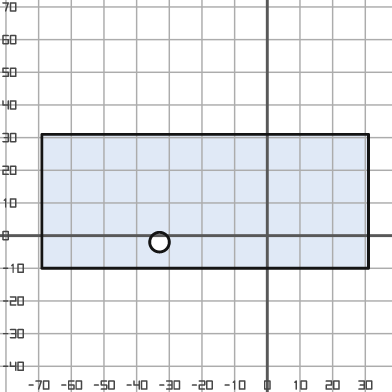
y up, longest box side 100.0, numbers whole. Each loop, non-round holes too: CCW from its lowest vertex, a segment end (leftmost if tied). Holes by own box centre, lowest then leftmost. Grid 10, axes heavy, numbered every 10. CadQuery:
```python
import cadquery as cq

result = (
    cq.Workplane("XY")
    .moveTo(-69.0, -10.0)
    .lineTo(31.0, -10.0)
    .lineTo(31.0, 31.0)
    .lineTo(-69.0, 31.0)
    .close()
    .moveTo(-33.0, -2.0)
    .circle(3.0)
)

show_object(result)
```